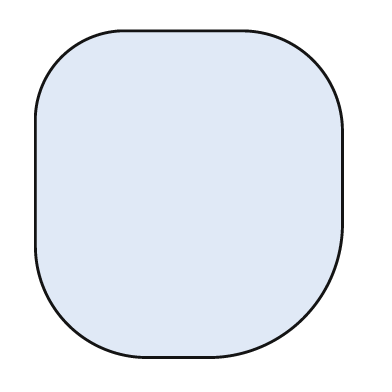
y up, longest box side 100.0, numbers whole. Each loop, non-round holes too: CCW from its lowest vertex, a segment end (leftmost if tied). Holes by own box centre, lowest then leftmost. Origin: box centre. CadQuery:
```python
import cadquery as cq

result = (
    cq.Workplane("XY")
    .moveTo(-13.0, -50.0)
    .lineTo(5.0, -50.0)
    .threePointArc((35.0, -38.0), (47.0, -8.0))
    .lineTo(47.0, 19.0)
    .threePointArc((38.0, 41.0), (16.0, 50.0))
    .lineTo(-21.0, 50.0)
    .threePointArc((-39.0, 42.0), (-47.0, 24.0))
    .lineTo(-47.0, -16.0)
    .threePointArc((-37.0, -40.0), (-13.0, -50.0))
    .close()
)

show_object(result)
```